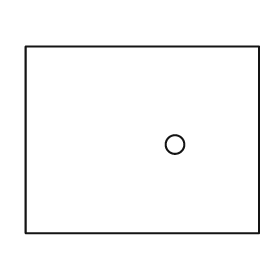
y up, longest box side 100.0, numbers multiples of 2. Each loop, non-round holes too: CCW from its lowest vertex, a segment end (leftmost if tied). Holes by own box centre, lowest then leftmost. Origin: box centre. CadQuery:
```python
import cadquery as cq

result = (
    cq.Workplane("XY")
    .moveTo(-50.0, -40.0)
    .lineTo(50.0, -40.0)
    .lineTo(50.0, 40.0)
    .lineTo(-50.0, 40.0)
    .close()
    .moveTo(14.0, -2.0)
    .circle(4.0)
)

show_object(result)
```